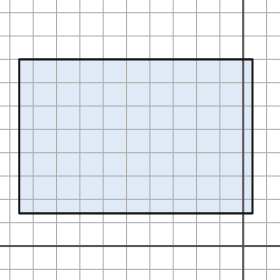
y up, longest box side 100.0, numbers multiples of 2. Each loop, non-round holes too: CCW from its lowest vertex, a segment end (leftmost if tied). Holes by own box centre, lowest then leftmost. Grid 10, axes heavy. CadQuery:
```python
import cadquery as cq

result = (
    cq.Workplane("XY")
    .moveTo(-96.0, 14.0)
    .lineTo(4.0, 14.0)
    .lineTo(4.0, 80.0)
    .lineTo(-96.0, 80.0)
    .close()
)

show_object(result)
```